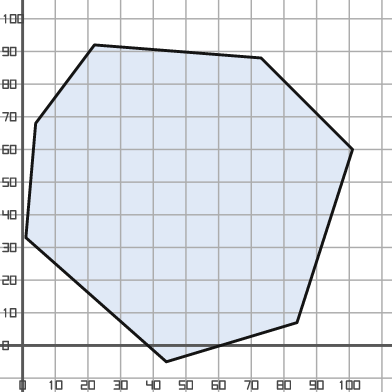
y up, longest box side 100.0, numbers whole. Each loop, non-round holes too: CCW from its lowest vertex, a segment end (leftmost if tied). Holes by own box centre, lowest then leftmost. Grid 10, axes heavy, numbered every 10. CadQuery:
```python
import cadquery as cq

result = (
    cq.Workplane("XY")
    .moveTo(44.0, -5.0)
    .lineTo(84.0, 7.0)
    .lineTo(101.0, 60.0)
    .lineTo(73.0, 88.0)
    .lineTo(22.0, 92.0)
    .lineTo(4.0, 68.0)
    .lineTo(1.0, 33.0)
    .close()
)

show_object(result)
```